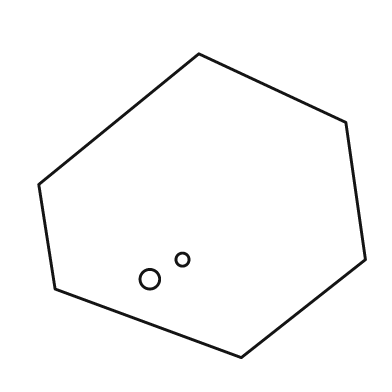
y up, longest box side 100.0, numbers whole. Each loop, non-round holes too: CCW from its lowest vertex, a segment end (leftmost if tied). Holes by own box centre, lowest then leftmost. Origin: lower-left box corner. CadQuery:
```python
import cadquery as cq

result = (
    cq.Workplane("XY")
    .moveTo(62.0, 0.0)
    .lineTo(100.0, 30.0)
    .lineTo(94.0, 72.0)
    .lineTo(49.0, 93.0)
    .lineTo(0.0, 53.0)
    .lineTo(5.0, 21.0)
    .close()
    .moveTo(34.0, 24.0)
    .circle(3.0)
    .moveTo(44.0, 30.0)
    .circle(2.0)
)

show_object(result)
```